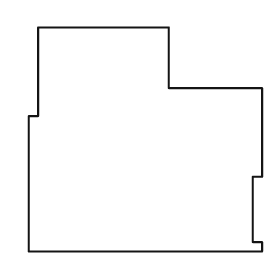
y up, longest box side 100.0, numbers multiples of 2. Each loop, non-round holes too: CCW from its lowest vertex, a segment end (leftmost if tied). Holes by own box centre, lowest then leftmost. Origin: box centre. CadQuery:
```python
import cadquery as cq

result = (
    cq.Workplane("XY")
    .moveTo(-50.0, -48.0)
    .lineTo(50.0, -48.0)
    .lineTo(50.0, -44.0)
    .lineTo(46.0, -44.0)
    .lineTo(46.0, -16.0)
    .lineTo(50.0, -16.0)
    .lineTo(50.0, 22.0)
    .lineTo(10.0, 22.0)
    .lineTo(10.0, 48.0)
    .lineTo(-46.0, 48.0)
    .lineTo(-46.0, 10.0)
    .lineTo(-50.0, 10.0)
    .close()
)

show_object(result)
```